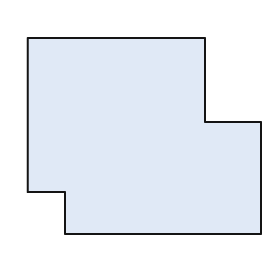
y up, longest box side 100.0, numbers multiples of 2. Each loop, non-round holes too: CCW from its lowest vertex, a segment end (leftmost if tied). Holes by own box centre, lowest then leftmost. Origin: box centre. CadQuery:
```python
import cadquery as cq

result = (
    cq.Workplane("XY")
    .moveTo(-34.0, -42.0)
    .lineTo(50.0, -42.0)
    .lineTo(50.0, 6.0)
    .lineTo(26.0, 6.0)
    .lineTo(26.0, 42.0)
    .lineTo(-50.0, 42.0)
    .lineTo(-50.0, -24.0)
    .lineTo(-34.0, -24.0)
    .close()
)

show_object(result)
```